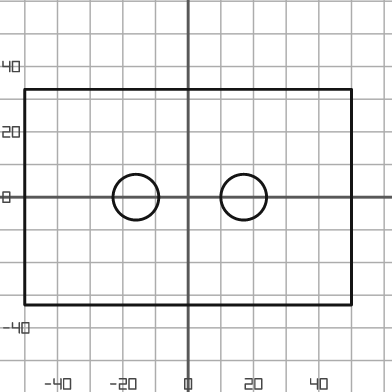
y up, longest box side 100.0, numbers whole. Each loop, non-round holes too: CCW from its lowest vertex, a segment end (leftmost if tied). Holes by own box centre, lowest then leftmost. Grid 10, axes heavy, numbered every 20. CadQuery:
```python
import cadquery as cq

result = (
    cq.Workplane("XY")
    .moveTo(-50.0, -33.0)
    .lineTo(50.0, -33.0)
    .lineTo(50.0, 33.0)
    .lineTo(-50.0, 33.0)
    .close()
    .moveTo(-16.0, 0.0)
    .circle(7.0)
    .moveTo(17.0, 0.0)
    .circle(7.0)
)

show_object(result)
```